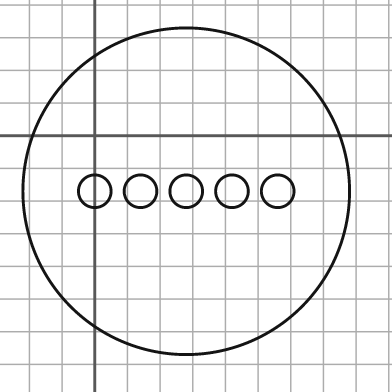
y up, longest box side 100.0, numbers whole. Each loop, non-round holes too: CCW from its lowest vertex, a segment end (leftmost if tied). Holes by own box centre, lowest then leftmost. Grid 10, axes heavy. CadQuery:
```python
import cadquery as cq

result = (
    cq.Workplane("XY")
    .moveTo(28.0, -17.0)
    .circle(50.0)
    .moveTo(0.0, -17.0)
    .circle(5.0)
    .moveTo(14.0, -17.0)
    .circle(5.0)
    .moveTo(28.0, -17.0)
    .circle(5.0)
    .moveTo(42.0, -17.0)
    .circle(5.0)
    .moveTo(56.0, -17.0)
    .circle(5.0)
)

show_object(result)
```